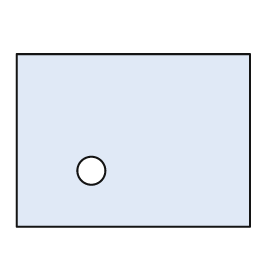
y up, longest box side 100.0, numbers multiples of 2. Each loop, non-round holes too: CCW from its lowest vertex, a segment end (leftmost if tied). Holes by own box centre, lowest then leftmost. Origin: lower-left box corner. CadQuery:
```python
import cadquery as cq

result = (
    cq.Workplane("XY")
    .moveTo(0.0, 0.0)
    .lineTo(100.0, 0.0)
    .lineTo(100.0, 74.0)
    .lineTo(0.0, 74.0)
    .close()
    .moveTo(32.0, 24.0)
    .circle(6.0)
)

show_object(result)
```